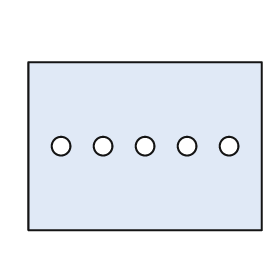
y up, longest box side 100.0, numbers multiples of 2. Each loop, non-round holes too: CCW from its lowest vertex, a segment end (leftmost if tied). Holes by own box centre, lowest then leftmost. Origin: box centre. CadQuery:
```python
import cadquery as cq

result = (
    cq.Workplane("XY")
    .moveTo(-50.0, -36.0)
    .lineTo(50.0, -36.0)
    .lineTo(50.0, 36.0)
    .lineTo(-50.0, 36.0)
    .close()
    .moveTo(-36.0, 0.0)
    .circle(4.0)
    .moveTo(-18.0, 0.0)
    .circle(4.0)
    .moveTo(0.0, 0.0)
    .circle(4.0)
    .moveTo(18.0, 0.0)
    .circle(4.0)
    .moveTo(36.0, 0.0)
    .circle(4.0)
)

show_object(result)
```